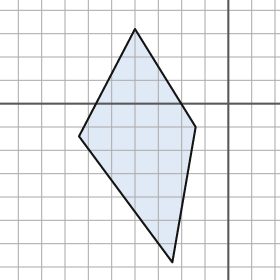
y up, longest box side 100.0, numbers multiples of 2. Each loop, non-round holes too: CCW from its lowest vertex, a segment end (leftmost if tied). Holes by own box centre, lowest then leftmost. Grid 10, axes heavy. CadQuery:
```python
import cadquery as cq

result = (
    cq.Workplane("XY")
    .moveTo(-24.0, -68.0)
    .lineTo(-14.0, -10.0)
    .lineTo(-40.0, 32.0)
    .lineTo(-64.0, -14.0)
    .close()
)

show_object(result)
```